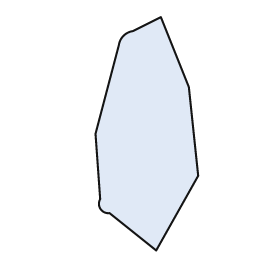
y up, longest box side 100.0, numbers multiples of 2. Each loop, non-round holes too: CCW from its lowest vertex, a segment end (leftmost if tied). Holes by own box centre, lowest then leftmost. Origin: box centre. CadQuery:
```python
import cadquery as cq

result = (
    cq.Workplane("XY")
    .moveTo(4.0, -50.0)
    .lineTo(22.0, -18.0)
    .lineTo(18.0, 20.0)
    .lineTo(6.0, 50.0)
    .lineTo(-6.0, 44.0)
    .threePointArc((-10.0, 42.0), (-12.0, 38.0))
    .lineTo(-22.0, 0.0)
    .lineTo(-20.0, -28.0)
    .threePointArc((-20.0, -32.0), (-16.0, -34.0))
    .close()
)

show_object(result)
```